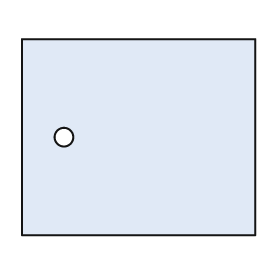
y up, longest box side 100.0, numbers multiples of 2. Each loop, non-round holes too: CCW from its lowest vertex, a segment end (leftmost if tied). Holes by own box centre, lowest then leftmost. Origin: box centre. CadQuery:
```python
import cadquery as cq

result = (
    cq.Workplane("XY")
    .moveTo(-50.0, -42.0)
    .lineTo(50.0, -42.0)
    .lineTo(50.0, 42.0)
    .lineTo(-50.0, 42.0)
    .close()
    .moveTo(-32.0, 0.0)
    .circle(4.0)
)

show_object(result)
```